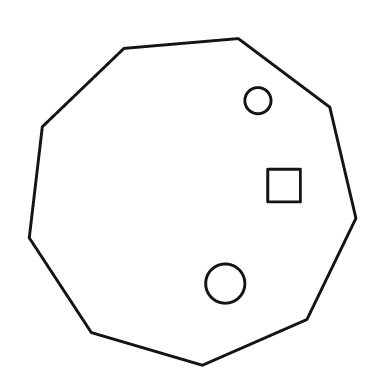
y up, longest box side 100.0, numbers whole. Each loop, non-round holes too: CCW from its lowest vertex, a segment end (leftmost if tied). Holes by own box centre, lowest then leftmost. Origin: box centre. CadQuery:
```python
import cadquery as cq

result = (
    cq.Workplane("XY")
    .moveTo(3.0, -50.0)
    .lineTo(35.0, -36.0)
    .lineTo(50.0, -5.0)
    .lineTo(42.0, 29.0)
    .lineTo(14.0, 50.0)
    .lineTo(-21.0, 47.0)
    .lineTo(-46.0, 23.0)
    .lineTo(-50.0, -11.0)
    .lineTo(-31.0, -40.0)
    .close()
    .moveTo(10.0, -25.0)
    .circle(6.0)
    .moveTo(23.0, 0.0)
    .lineTo(33.0, 0.0)
    .lineTo(33.0, 10.0)
    .lineTo(23.0, 10.0)
    .close()
    .moveTo(20.0, 31.0)
    .circle(4.0)
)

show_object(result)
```